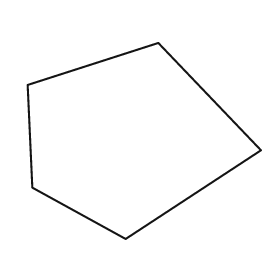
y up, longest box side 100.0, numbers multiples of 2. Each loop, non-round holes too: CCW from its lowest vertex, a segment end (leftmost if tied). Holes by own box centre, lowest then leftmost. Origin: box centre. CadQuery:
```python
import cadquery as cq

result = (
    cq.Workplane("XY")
    .moveTo(-8.0, -42.0)
    .lineTo(50.0, -4.0)
    .lineTo(6.0, 42.0)
    .lineTo(-50.0, 24.0)
    .lineTo(-48.0, -20.0)
    .close()
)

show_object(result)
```